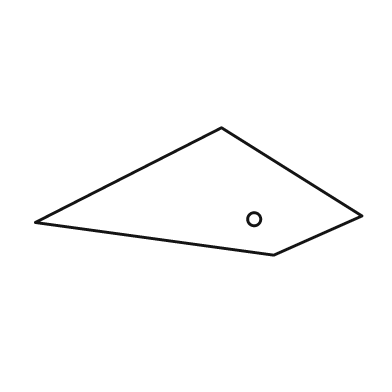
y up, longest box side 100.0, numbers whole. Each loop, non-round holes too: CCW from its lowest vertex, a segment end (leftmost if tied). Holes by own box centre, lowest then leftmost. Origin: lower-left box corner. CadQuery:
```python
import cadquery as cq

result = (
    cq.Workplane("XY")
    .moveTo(73.0, 0.0)
    .lineTo(100.0, 12.0)
    .lineTo(57.0, 39.0)
    .lineTo(0.0, 10.0)
    .close()
    .moveTo(67.0, 11.0)
    .circle(2.0)
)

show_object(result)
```